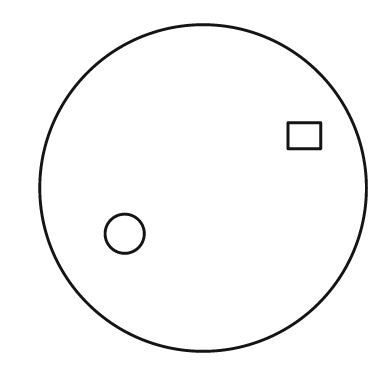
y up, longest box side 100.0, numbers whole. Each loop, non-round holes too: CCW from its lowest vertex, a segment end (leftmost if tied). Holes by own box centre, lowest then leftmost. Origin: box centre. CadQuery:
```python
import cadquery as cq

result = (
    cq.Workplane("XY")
    .moveTo(0.0, 0.0)
    .circle(50.0)
    .moveTo(-24.0, -14.0)
    .circle(6.0)
    .moveTo(26.0, 12.0)
    .lineTo(36.0, 12.0)
    .lineTo(36.0, 20.0)
    .lineTo(26.0, 20.0)
    .close()
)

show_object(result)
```